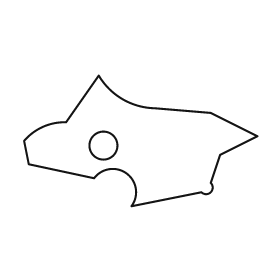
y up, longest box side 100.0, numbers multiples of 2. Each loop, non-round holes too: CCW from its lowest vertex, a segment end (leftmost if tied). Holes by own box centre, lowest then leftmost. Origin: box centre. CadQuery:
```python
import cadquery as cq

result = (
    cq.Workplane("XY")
    .moveTo(-4.0, -28.0)
    .lineTo(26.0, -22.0)
    .threePointArc((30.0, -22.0), (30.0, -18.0))
    .lineTo(34.0, -6.0)
    .lineTo(50.0, 2.0)
    .lineTo(30.0, 12.0)
    .lineTo(6.0, 14.0)
    .threePointArc((-8.0, 18.0), (-18.0, 28.0))
    .lineTo(-32.0, 8.0)
    .threePointArc((-42.0, 6.0), (-50.0, 0.0))
    .lineTo(-48.0, -10.0)
    .lineTo(-20.0, -16.0)
    .threePointArc((-6.0, -14.0), (-4.0, -28.0))
    .close()
    .moveTo(-16.0, -2.0)
    .circle(6.0)
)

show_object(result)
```